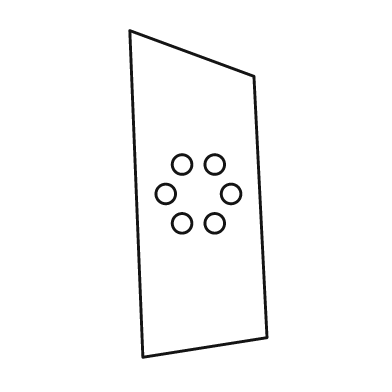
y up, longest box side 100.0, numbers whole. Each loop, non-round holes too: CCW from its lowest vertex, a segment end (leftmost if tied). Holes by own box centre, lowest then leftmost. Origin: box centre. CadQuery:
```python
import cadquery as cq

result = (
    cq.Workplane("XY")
    .moveTo(-17.0, -50.0)
    .lineTo(21.0, -44.0)
    .lineTo(17.0, 36.0)
    .lineTo(-21.0, 50.0)
    .close()
    .moveTo(-5.0, -9.0)
    .circle(3.0)
    .moveTo(5.0, -9.0)
    .circle(3.0)
    .moveTo(-10.0, 0.0)
    .circle(3.0)
    .moveTo(10.0, 0.0)
    .circle(3.0)
    .moveTo(-5.0, 9.0)
    .circle(3.0)
    .moveTo(5.0, 9.0)
    .circle(3.0)
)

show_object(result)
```